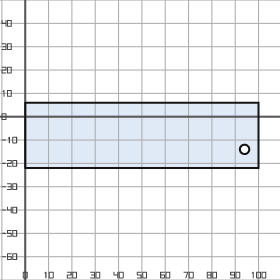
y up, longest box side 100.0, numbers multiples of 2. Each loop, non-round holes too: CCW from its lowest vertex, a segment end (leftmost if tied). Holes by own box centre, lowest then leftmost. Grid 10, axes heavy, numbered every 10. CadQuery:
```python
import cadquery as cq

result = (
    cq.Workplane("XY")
    .moveTo(0.0, -22.0)
    .lineTo(100.0, -22.0)
    .lineTo(100.0, 6.0)
    .lineTo(0.0, 6.0)
    .close()
    .moveTo(94.0, -14.0)
    .circle(2.0)
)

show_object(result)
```